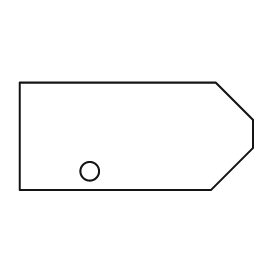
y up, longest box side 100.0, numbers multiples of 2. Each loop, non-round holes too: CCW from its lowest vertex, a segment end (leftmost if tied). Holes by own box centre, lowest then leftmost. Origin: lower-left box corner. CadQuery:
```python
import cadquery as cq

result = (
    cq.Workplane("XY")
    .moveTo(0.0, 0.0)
    .lineTo(82.0, 0.0)
    .lineTo(100.0, 18.0)
    .lineTo(100.0, 30.0)
    .lineTo(84.0, 46.0)
    .lineTo(0.0, 46.0)
    .close()
    .moveTo(30.0, 8.0)
    .circle(4.0)
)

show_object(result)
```